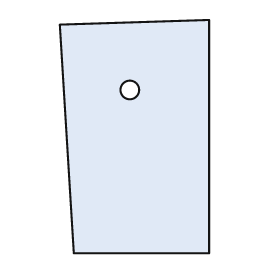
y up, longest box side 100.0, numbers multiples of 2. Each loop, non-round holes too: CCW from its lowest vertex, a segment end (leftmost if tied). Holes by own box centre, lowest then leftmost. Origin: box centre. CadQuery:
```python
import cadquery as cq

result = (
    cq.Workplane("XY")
    .moveTo(-26.0, -50.0)
    .lineTo(32.0, -50.0)
    .lineTo(32.0, 50.0)
    .lineTo(-32.0, 48.0)
    .close()
    .moveTo(-2.0, 20.0)
    .circle(4.0)
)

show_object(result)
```